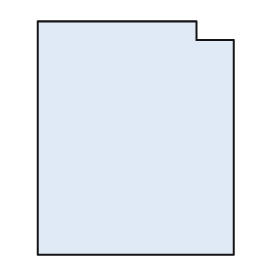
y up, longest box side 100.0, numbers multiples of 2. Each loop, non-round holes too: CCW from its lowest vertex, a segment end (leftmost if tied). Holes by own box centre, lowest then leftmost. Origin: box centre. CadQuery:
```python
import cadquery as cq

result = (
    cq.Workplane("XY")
    .moveTo(-42.0, -50.0)
    .lineTo(42.0, -50.0)
    .lineTo(42.0, 42.0)
    .lineTo(26.0, 42.0)
    .lineTo(26.0, 50.0)
    .lineTo(-42.0, 50.0)
    .close()
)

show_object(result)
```